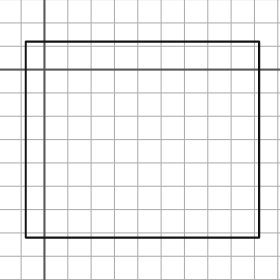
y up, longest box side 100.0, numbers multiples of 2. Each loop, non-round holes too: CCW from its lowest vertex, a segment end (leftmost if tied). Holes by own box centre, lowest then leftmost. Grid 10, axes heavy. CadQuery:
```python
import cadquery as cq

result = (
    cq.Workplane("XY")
    .moveTo(-8.0, -72.0)
    .lineTo(92.0, -72.0)
    .lineTo(92.0, 12.0)
    .lineTo(-8.0, 12.0)
    .close()
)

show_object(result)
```